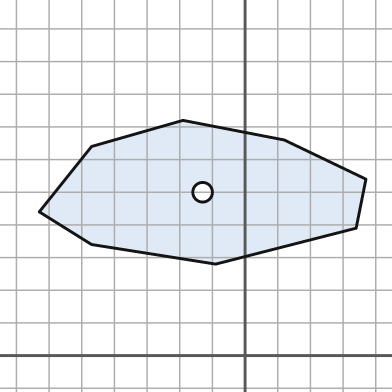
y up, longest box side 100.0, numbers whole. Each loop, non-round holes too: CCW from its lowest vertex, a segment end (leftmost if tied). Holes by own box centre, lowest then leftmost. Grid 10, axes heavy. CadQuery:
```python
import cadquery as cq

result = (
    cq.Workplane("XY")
    .moveTo(-9.0, 28.0)
    .lineTo(34.0, 39.0)
    .lineTo(37.0, 54.0)
    .lineTo(12.0, 66.0)
    .lineTo(-19.0, 72.0)
    .lineTo(-47.0, 64.0)
    .lineTo(-63.0, 44.0)
    .lineTo(-47.0, 34.0)
    .close()
    .moveTo(-13.0, 50.0)
    .circle(3.0)
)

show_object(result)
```